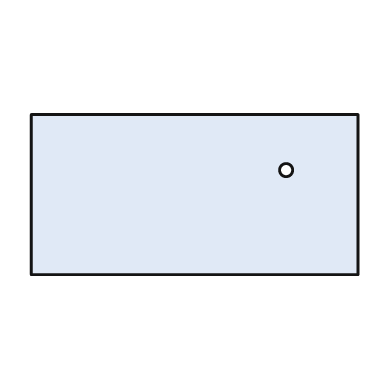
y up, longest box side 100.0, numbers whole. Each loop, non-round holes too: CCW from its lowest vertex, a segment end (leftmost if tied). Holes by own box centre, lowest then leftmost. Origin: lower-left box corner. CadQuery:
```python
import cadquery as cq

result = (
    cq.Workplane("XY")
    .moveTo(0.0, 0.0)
    .lineTo(100.0, 0.0)
    .lineTo(100.0, 49.0)
    .lineTo(0.0, 49.0)
    .close()
    .moveTo(78.0, 32.0)
    .circle(2.0)
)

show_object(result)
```